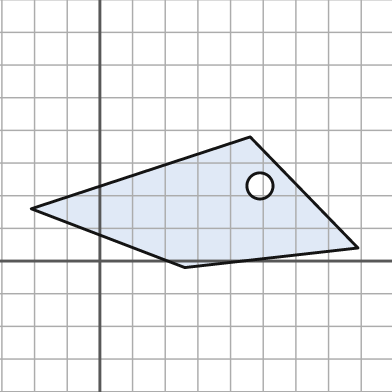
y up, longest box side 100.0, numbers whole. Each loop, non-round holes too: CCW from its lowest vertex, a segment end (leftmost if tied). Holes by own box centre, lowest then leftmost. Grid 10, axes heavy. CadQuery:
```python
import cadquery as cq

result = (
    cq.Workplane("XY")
    .moveTo(26.0, -2.0)
    .lineTo(79.0, 4.0)
    .lineTo(46.0, 38.0)
    .lineTo(-21.0, 16.0)
    .close()
    .moveTo(49.0, 23.0)
    .circle(4.0)
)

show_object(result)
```